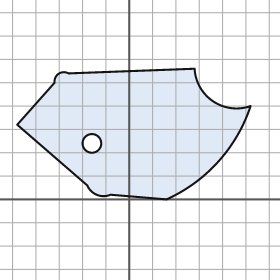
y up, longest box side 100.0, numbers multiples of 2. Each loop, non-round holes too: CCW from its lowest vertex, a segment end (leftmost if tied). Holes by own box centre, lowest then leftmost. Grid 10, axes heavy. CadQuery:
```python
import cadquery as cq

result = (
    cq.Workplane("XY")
    .moveTo(16.0, 0.0)
    .threePointArc((38.0, 16.0), (52.0, 40.0))
    .threePointArc((36.0, 42.0), (28.0, 56.0))
    .lineTo(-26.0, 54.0)
    .threePointArc((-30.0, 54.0), (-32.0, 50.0))
    .lineTo(-48.0, 32.0)
    .lineTo(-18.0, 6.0)
    .threePointArc((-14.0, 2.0), (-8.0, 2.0))
    .close()
    .moveTo(-16.0, 24.0)
    .circle(4.0)
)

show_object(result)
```